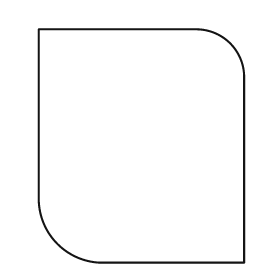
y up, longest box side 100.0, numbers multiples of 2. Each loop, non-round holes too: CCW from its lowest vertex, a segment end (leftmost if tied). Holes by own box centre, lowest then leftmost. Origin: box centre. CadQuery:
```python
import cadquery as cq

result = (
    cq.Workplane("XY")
    .moveTo(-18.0, -50.0)
    .lineTo(44.0, -50.0)
    .lineTo(44.0, 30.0)
    .threePointArc((38.0, 44.0), (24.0, 50.0))
    .lineTo(-44.0, 50.0)
    .lineTo(-44.0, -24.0)
    .threePointArc((-36.0, -42.0), (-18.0, -50.0))
    .close()
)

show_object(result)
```